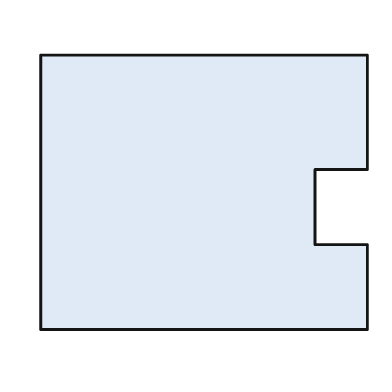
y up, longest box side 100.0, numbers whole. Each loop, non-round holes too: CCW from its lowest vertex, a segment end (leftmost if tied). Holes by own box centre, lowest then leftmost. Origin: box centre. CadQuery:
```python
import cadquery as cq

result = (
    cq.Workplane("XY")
    .moveTo(-50.0, -42.0)
    .lineTo(50.0, -42.0)
    .lineTo(50.0, -16.0)
    .lineTo(34.0, -16.0)
    .lineTo(34.0, 7.0)
    .lineTo(50.0, 7.0)
    .lineTo(50.0, 42.0)
    .lineTo(-50.0, 42.0)
    .close()
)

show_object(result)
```